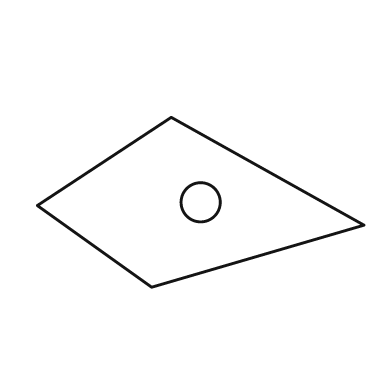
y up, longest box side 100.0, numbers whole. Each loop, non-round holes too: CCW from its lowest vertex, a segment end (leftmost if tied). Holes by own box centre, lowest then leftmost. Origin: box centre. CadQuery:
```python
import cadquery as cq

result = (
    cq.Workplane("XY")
    .moveTo(-15.0, -26.0)
    .lineTo(50.0, -7.0)
    .lineTo(-9.0, 26.0)
    .lineTo(-50.0, -1.0)
    .close()
    .moveTo(0.0, 0.0)
    .circle(6.0)
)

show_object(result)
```